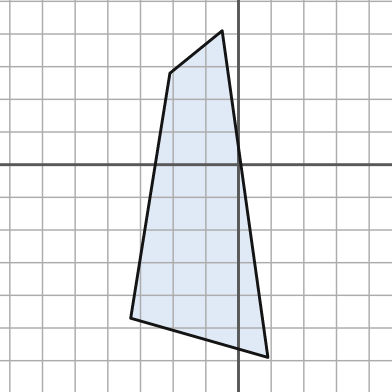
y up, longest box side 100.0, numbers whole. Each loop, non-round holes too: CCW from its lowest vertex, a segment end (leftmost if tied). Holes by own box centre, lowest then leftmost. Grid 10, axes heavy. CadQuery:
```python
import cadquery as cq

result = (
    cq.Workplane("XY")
    .moveTo(9.0, -59.0)
    .lineTo(-5.0, 41.0)
    .lineTo(-21.0, 28.0)
    .lineTo(-33.0, -47.0)
    .close()
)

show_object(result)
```